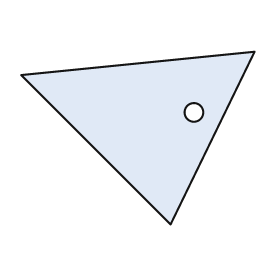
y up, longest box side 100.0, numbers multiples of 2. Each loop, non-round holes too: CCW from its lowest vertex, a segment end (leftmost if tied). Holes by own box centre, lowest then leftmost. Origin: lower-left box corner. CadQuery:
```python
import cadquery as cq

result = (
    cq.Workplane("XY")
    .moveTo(64.0, 0.0)
    .lineTo(100.0, 74.0)
    .lineTo(0.0, 64.0)
    .close()
    .moveTo(74.0, 48.0)
    .circle(4.0)
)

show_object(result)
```